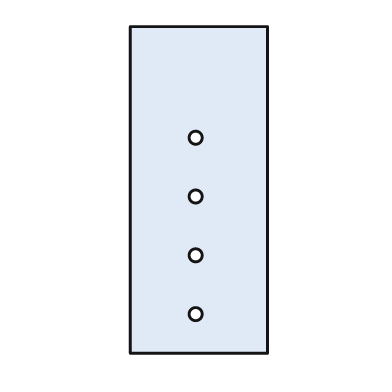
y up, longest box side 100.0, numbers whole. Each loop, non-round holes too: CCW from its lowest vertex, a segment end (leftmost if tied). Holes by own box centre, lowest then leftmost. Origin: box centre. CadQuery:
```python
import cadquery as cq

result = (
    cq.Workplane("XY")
    .moveTo(-21.0, -50.0)
    .lineTo(21.0, -50.0)
    .lineTo(21.0, 50.0)
    .lineTo(-21.0, 50.0)
    .close()
    .moveTo(-1.0, -38.0)
    .circle(2.0)
    .moveTo(-1.0, -20.0)
    .circle(2.0)
    .moveTo(-1.0, -2.0)
    .circle(2.0)
    .moveTo(-1.0, 16.0)
    .circle(2.0)
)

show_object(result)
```